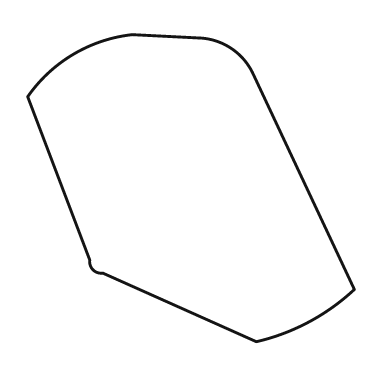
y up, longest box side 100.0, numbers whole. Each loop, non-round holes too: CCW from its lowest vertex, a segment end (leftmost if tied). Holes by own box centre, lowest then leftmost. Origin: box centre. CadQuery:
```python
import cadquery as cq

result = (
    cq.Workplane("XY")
    .moveTo(20.0, -47.0)
    .threePointArc((36.0, -41.0), (50.0, -31.0))
    .lineTo(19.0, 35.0)
    .threePointArc((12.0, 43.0), (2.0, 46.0))
    .lineTo(-18.0, 47.0)
    .threePointArc((-36.0, 41.0), (-50.0, 28.0))
    .lineTo(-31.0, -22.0)
    .threePointArc((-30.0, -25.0), (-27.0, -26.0))
    .close()
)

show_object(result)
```